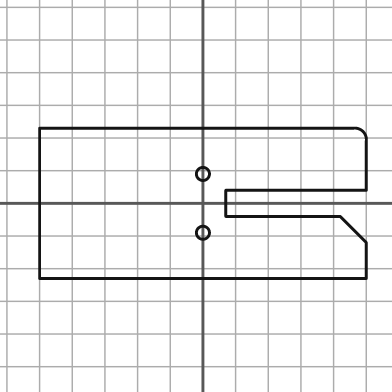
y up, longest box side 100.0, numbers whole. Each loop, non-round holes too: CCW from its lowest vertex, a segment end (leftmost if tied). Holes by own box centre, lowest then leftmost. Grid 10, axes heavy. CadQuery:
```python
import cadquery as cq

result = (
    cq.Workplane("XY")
    .moveTo(-50.0, -23.0)
    .lineTo(50.0, -23.0)
    .lineTo(50.0, -12.0)
    .lineTo(42.0, -4.0)
    .lineTo(7.0, -4.0)
    .lineTo(7.0, 4.0)
    .lineTo(50.0, 4.0)
    .lineTo(50.0, 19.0)
    .threePointArc((49.0, 22.0), (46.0, 23.0))
    .lineTo(-50.0, 23.0)
    .close()
    .moveTo(0.0, -9.0)
    .circle(2.0)
    .moveTo(0.0, 9.0)
    .circle(2.0)
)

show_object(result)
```